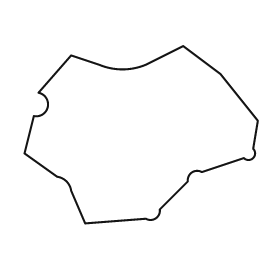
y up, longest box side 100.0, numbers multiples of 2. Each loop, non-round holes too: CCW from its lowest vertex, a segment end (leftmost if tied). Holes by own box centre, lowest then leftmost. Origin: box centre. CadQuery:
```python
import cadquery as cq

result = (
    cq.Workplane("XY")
    .moveTo(-24.0, -38.0)
    .lineTo(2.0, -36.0)
    .threePointArc((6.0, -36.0), (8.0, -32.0))
    .lineTo(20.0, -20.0)
    .threePointArc((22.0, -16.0), (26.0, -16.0))
    .lineTo(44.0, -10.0)
    .threePointArc((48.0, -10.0), (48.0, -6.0))
    .lineTo(50.0, 6.0)
    .lineTo(34.0, 26.0)
    .lineTo(18.0, 38.0)
    .lineTo(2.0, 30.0)
    .threePointArc((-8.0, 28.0), (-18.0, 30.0))
    .lineTo(-30.0, 34.0)
    .lineTo(-44.0, 18.0)
    .threePointArc((-40.0, 12.0), (-46.0, 8.0))
    .lineTo(-50.0, -8.0)
    .lineTo(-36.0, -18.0)
    .threePointArc((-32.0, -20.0), (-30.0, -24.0))
    .close()
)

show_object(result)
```